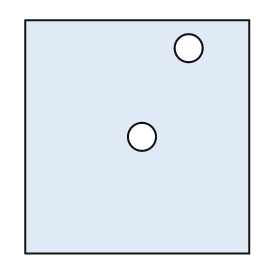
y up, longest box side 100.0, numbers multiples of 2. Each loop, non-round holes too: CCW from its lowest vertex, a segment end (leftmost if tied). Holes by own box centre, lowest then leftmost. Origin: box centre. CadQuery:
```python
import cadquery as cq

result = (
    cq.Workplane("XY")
    .moveTo(-48.0, -50.0)
    .lineTo(48.0, -50.0)
    .lineTo(48.0, 50.0)
    .lineTo(-48.0, 50.0)
    .close()
    .moveTo(2.0, 0.0)
    .circle(6.0)
    .moveTo(22.0, 38.0)
    .circle(6.0)
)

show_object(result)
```